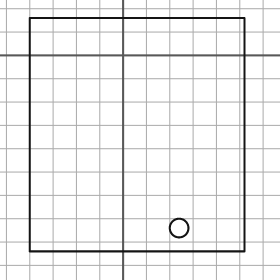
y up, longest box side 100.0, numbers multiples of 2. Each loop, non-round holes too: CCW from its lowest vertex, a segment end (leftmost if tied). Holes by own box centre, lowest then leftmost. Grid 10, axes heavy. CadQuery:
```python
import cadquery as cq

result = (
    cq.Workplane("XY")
    .moveTo(-40.0, -84.0)
    .lineTo(52.0, -84.0)
    .lineTo(52.0, 16.0)
    .lineTo(-40.0, 16.0)
    .close()
    .moveTo(24.0, -74.0)
    .circle(4.0)
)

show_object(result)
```